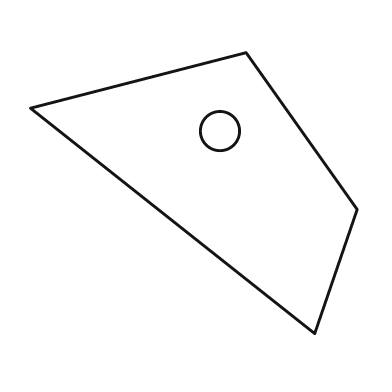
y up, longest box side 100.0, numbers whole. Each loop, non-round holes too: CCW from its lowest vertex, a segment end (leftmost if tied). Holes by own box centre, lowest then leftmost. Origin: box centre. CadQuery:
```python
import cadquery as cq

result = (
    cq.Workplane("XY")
    .moveTo(37.0, -43.0)
    .lineTo(50.0, -5.0)
    .lineTo(16.0, 43.0)
    .lineTo(-50.0, 26.0)
    .close()
    .moveTo(8.0, 19.0)
    .circle(6.0)
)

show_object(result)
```